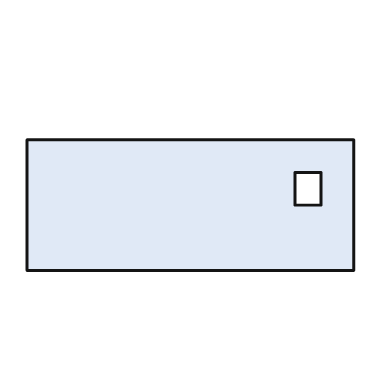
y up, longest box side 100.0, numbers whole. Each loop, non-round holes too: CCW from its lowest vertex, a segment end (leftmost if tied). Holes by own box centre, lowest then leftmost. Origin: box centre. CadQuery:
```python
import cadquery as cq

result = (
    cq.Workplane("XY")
    .moveTo(-50.0, -20.0)
    .lineTo(50.0, -20.0)
    .lineTo(50.0, 20.0)
    .lineTo(-50.0, 20.0)
    .close()
    .moveTo(32.0, 0.0)
    .lineTo(40.0, 0.0)
    .lineTo(40.0, 10.0)
    .lineTo(32.0, 10.0)
    .close()
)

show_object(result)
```